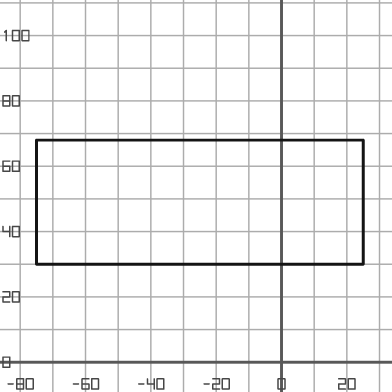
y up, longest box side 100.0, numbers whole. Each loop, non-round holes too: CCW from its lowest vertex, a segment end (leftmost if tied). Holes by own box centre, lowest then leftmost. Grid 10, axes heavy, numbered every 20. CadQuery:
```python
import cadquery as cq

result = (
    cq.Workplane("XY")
    .moveTo(-75.0, 30.0)
    .lineTo(25.0, 30.0)
    .lineTo(25.0, 68.0)
    .lineTo(-75.0, 68.0)
    .close()
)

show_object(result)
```